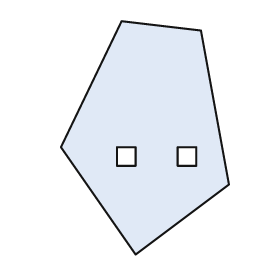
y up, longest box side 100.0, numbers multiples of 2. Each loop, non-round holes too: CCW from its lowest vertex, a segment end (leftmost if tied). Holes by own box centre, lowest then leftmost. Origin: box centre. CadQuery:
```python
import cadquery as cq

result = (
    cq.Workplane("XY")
    .moveTo(-4.0, -50.0)
    .lineTo(36.0, -20.0)
    .lineTo(24.0, 46.0)
    .lineTo(-10.0, 50.0)
    .lineTo(-36.0, -4.0)
    .close()
    .moveTo(-12.0, -12.0)
    .lineTo(-4.0, -12.0)
    .lineTo(-4.0, -4.0)
    .lineTo(-12.0, -4.0)
    .close()
    .moveTo(14.0, -12.0)
    .lineTo(22.0, -12.0)
    .lineTo(22.0, -4.0)
    .lineTo(14.0, -4.0)
    .close()
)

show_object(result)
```